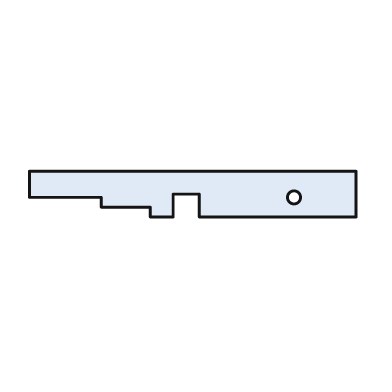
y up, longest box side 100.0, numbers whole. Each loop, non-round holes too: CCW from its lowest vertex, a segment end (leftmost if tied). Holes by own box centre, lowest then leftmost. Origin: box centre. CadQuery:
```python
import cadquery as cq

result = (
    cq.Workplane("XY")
    .moveTo(-13.0, -7.0)
    .lineTo(-6.0, -7.0)
    .lineTo(-6.0, 0.0)
    .lineTo(2.0, 0.0)
    .lineTo(2.0, -7.0)
    .lineTo(50.0, -7.0)
    .lineTo(50.0, 7.0)
    .lineTo(-50.0, 7.0)
    .lineTo(-50.0, -1.0)
    .lineTo(-28.0, -1.0)
    .lineTo(-28.0, -4.0)
    .lineTo(-13.0, -4.0)
    .close()
    .moveTo(31.0, -1.0)
    .circle(2.0)
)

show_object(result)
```